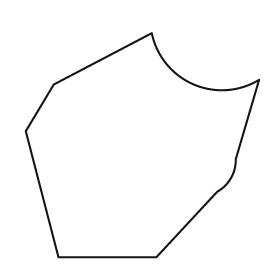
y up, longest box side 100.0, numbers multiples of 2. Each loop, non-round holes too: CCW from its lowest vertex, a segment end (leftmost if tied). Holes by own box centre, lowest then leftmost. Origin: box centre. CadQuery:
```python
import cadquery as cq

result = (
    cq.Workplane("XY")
    .moveTo(-36.0, -48.0)
    .lineTo(6.0, -48.0)
    .lineTo(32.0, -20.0)
    .threePointArc((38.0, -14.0), (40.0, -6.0))
    .lineTo(50.0, 28.0)
    .threePointArc((22.0, 26.0), (4.0, 48.0))
    .lineTo(-38.0, 26.0)
    .lineTo(-50.0, 6.0)
    .close()
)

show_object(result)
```